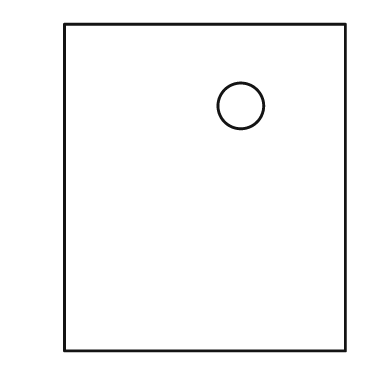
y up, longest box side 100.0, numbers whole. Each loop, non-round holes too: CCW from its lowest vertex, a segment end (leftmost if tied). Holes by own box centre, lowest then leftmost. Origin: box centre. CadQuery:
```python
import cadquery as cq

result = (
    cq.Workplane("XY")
    .moveTo(-43.0, -50.0)
    .lineTo(43.0, -50.0)
    .lineTo(43.0, 50.0)
    .lineTo(-43.0, 50.0)
    .close()
    .moveTo(11.0, 25.0)
    .circle(7.0)
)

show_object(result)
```